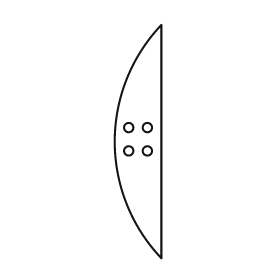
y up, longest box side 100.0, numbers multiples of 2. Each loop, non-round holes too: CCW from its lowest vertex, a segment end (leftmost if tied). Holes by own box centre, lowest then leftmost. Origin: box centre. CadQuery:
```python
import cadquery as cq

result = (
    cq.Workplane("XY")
    .moveTo(10.0, -50.0)
    .lineTo(10.0, 50.0)
    .threePointArc((-10.0, 0.0), (10.0, -50.0))
    .close()
    .moveTo(-4.0, -4.0)
    .circle(2.0)
    .moveTo(4.0, -4.0)
    .circle(2.0)
    .moveTo(-4.0, 6.0)
    .circle(2.0)
    .moveTo(4.0, 6.0)
    .circle(2.0)
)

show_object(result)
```